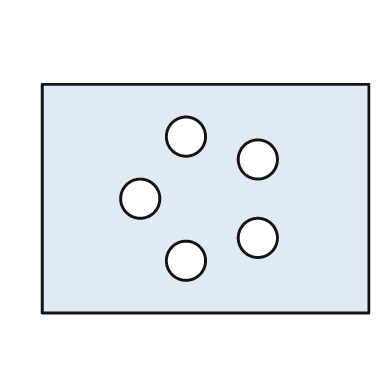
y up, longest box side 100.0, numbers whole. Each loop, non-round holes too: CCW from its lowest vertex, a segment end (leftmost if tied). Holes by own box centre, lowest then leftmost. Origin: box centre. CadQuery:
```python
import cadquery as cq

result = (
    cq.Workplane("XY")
    .moveTo(-50.0, -35.0)
    .lineTo(50.0, -35.0)
    .lineTo(50.0, 35.0)
    .lineTo(-50.0, 35.0)
    .close()
    .moveTo(-6.0, -19.0)
    .circle(6.0)
    .moveTo(16.0, -12.0)
    .circle(6.0)
    .moveTo(-20.0, 0.0)
    .circle(6.0)
    .moveTo(16.0, 12.0)
    .circle(6.0)
    .moveTo(-6.0, 19.0)
    .circle(6.0)
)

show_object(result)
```